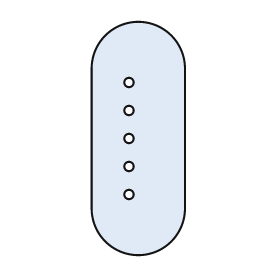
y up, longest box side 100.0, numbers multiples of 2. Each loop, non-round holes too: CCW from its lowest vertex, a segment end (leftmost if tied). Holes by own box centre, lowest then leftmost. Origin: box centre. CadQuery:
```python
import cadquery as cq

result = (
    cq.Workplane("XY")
    .moveTo(-20.0, -30.0)
    .threePointArc((0.0, -50.0), (20.0, -30.0))
    .lineTo(20.0, 30.0)
    .threePointArc((0.0, 50.0), (-20.0, 30.0))
    .close()
    .moveTo(-4.0, -24.0)
    .circle(2.0)
    .moveTo(-4.0, -12.0)
    .circle(2.0)
    .moveTo(-4.0, 0.0)
    .circle(2.0)
    .moveTo(-4.0, 12.0)
    .circle(2.0)
    .moveTo(-4.0, 24.0)
    .circle(2.0)
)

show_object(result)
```